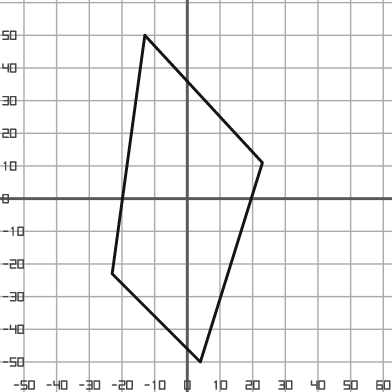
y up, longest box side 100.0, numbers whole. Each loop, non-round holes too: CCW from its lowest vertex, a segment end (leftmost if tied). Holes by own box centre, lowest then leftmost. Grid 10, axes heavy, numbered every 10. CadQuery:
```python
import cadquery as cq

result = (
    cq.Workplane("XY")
    .moveTo(4.0, -50.0)
    .lineTo(23.0, 11.0)
    .lineTo(-13.0, 50.0)
    .lineTo(-23.0, -23.0)
    .close()
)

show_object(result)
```